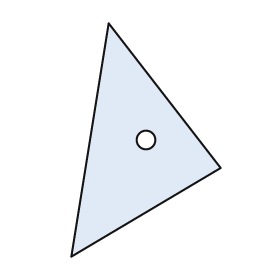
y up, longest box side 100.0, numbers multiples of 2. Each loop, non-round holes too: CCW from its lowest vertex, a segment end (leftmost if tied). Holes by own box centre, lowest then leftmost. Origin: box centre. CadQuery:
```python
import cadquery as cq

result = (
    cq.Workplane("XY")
    .moveTo(-32.0, -50.0)
    .lineTo(32.0, -12.0)
    .lineTo(-16.0, 50.0)
    .close()
    .moveTo(0.0, 0.0)
    .circle(4.0)
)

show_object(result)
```